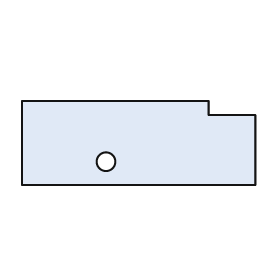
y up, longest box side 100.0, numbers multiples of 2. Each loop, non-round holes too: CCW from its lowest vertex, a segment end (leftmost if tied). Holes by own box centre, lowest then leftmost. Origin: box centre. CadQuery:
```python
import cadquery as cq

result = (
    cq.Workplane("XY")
    .moveTo(-50.0, -18.0)
    .lineTo(50.0, -18.0)
    .lineTo(50.0, 12.0)
    .lineTo(30.0, 12.0)
    .lineTo(30.0, 18.0)
    .lineTo(-50.0, 18.0)
    .close()
    .moveTo(-14.0, -8.0)
    .circle(4.0)
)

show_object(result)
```